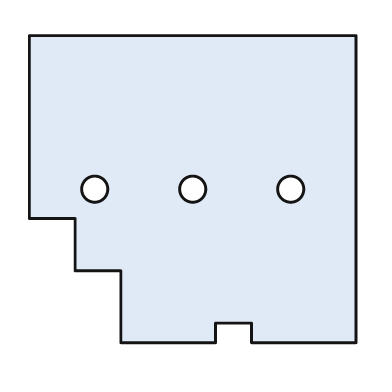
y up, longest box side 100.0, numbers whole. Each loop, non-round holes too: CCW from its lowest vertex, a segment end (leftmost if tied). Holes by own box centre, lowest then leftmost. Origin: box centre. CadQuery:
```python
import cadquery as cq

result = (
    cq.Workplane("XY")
    .moveTo(-22.0, -47.0)
    .lineTo(7.0, -47.0)
    .lineTo(7.0, -41.0)
    .lineTo(18.0, -41.0)
    .lineTo(18.0, -47.0)
    .lineTo(50.0, -47.0)
    .lineTo(50.0, 47.0)
    .lineTo(-50.0, 47.0)
    .lineTo(-50.0, -9.0)
    .lineTo(-36.0, -9.0)
    .lineTo(-36.0, -25.0)
    .lineTo(-22.0, -25.0)
    .close()
    .moveTo(-30.0, 0.0)
    .circle(4.0)
    .moveTo(0.0, 0.0)
    .circle(4.0)
    .moveTo(30.0, 0.0)
    .circle(4.0)
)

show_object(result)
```